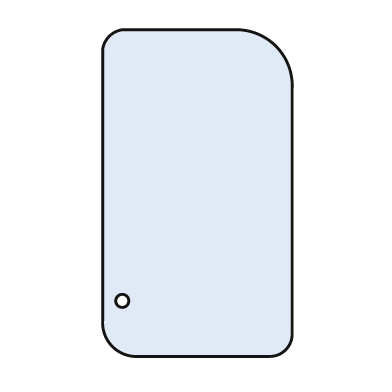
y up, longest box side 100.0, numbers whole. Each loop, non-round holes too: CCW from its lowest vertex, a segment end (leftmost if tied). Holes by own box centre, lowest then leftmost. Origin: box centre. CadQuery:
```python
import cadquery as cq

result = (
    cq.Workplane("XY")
    .moveTo(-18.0, -50.0)
    .lineTo(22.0, -50.0)
    .threePointArc((27.0, -48.0), (29.0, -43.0))
    .lineTo(29.0, 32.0)
    .threePointArc((24.0, 45.0), (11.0, 50.0))
    .lineTo(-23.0, 50.0)
    .threePointArc((-27.0, 48.0), (-29.0, 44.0))
    .lineTo(-29.0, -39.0)
    .threePointArc((-26.0, -47.0), (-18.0, -50.0))
    .close()
    .moveTo(-23.0, -33.0)
    .circle(2.0)
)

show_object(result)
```